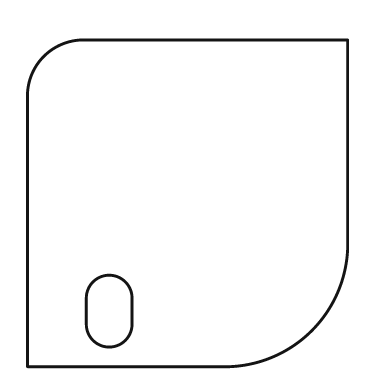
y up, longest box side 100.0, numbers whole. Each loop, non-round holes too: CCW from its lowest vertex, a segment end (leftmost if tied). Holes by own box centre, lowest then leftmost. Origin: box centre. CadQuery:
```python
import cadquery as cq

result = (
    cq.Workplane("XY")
    .moveTo(-49.0, -50.0)
    .lineTo(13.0, -50.0)
    .threePointArc((38.0, -39.0), (49.0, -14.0))
    .lineTo(49.0, 50.0)
    .lineTo(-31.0, 50.0)
    .threePointArc((-44.0, 45.0), (-49.0, 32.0))
    .close()
    .moveTo(-31.0, -37.0)
    .threePointArc((-24.0, -44.0), (-17.0, -37.0))
    .lineTo(-17.0, -29.0)
    .threePointArc((-24.0, -22.0), (-31.0, -29.0))
    .close()
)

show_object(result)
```